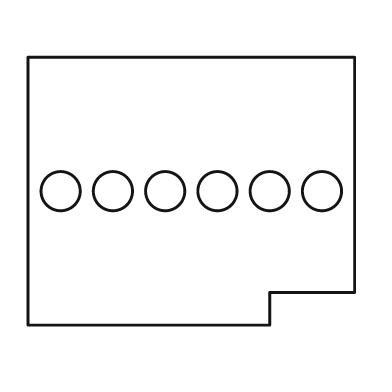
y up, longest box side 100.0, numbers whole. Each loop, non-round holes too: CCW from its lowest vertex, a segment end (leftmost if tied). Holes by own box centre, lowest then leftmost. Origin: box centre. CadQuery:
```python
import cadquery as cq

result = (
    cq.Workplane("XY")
    .moveTo(-50.0, -41.0)
    .lineTo(24.0, -41.0)
    .lineTo(24.0, -31.0)
    .lineTo(50.0, -31.0)
    .lineTo(50.0, 41.0)
    .lineTo(-50.0, 41.0)
    .close()
    .moveTo(-40.0, 0.0)
    .circle(6.0)
    .moveTo(-24.0, 0.0)
    .circle(6.0)
    .moveTo(-8.0, 0.0)
    .circle(6.0)
    .moveTo(8.0, 0.0)
    .circle(6.0)
    .moveTo(24.0, 0.0)
    .circle(6.0)
    .moveTo(40.0, 0.0)
    .circle(6.0)
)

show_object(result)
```